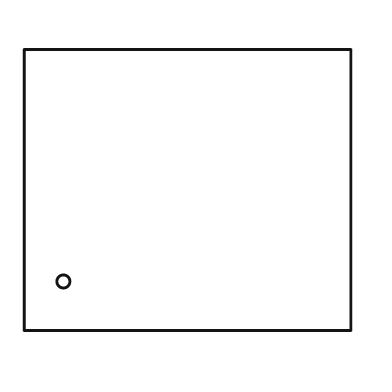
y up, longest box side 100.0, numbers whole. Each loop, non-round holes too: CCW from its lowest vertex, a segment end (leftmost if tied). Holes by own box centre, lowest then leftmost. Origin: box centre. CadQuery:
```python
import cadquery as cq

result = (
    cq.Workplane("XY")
    .moveTo(-50.0, -43.0)
    .lineTo(50.0, -43.0)
    .lineTo(50.0, 43.0)
    .lineTo(-50.0, 43.0)
    .close()
    .moveTo(-38.0, -28.0)
    .circle(2.0)
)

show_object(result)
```